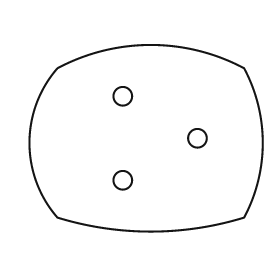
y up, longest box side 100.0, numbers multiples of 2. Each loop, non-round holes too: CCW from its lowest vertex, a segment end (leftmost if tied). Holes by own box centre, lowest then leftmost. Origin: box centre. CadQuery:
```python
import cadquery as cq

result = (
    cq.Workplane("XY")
    .moveTo(-38.0, -34.0)
    .threePointArc((2.0, -40.0), (42.0, -34.0))
    .threePointArc((50.0, -2.0), (42.0, 30.0))
    .threePointArc((2.0, 40.0), (-38.0, 30.0))
    .threePointArc((-50.0, -2.0), (-38.0, -34.0))
    .close()
    .moveTo(-10.0, -18.0)
    .circle(4.0)
    .moveTo(22.0, 0.0)
    .circle(4.0)
    .moveTo(-10.0, 18.0)
    .circle(4.0)
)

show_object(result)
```